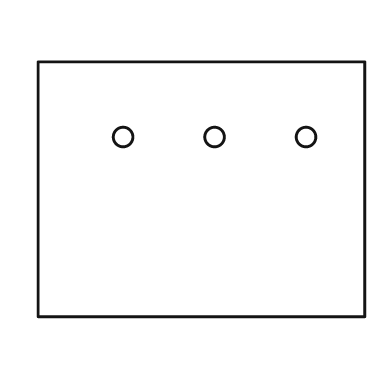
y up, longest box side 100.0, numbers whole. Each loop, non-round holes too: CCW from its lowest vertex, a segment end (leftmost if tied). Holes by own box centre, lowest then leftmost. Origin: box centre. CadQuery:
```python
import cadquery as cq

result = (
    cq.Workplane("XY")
    .moveTo(-50.0, -39.0)
    .lineTo(50.0, -39.0)
    .lineTo(50.0, 39.0)
    .lineTo(-50.0, 39.0)
    .close()
    .moveTo(-24.0, 16.0)
    .circle(3.0)
    .moveTo(4.0, 16.0)
    .circle(3.0)
    .moveTo(32.0, 16.0)
    .circle(3.0)
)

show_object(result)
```